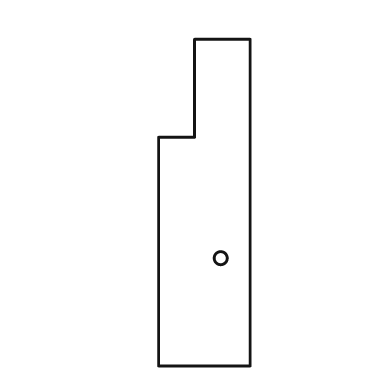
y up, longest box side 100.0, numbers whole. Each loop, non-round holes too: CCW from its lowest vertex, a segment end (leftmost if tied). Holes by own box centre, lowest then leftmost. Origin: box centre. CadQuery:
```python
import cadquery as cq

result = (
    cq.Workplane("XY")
    .moveTo(-14.0, -50.0)
    .lineTo(14.0, -50.0)
    .lineTo(14.0, 50.0)
    .lineTo(-3.0, 50.0)
    .lineTo(-3.0, 20.0)
    .lineTo(-14.0, 20.0)
    .close()
    .moveTo(5.0, -17.0)
    .circle(2.0)
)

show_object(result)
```